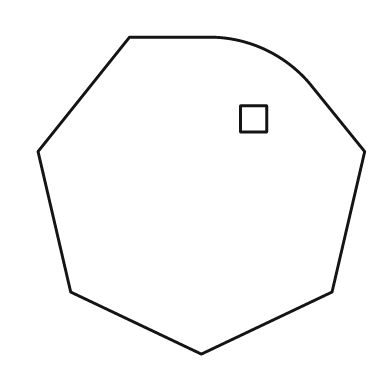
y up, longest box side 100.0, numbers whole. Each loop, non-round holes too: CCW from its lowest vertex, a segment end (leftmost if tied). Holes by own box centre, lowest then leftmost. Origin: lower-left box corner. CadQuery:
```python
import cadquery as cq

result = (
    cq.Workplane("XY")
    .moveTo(50.0, 0.0)
    .lineTo(90.0, 19.0)
    .lineTo(100.0, 62.0)
    .lineTo(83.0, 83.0)
    .threePointArc((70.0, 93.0), (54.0, 97.0))
    .lineTo(28.0, 97.0)
    .lineTo(0.0, 62.0)
    .lineTo(10.0, 19.0)
    .close()
    .moveTo(62.0, 68.0)
    .lineTo(70.0, 68.0)
    .lineTo(70.0, 76.0)
    .lineTo(62.0, 76.0)
    .close()
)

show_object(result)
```